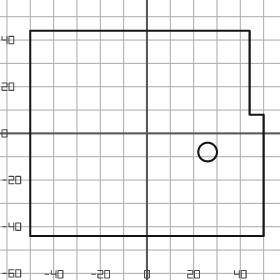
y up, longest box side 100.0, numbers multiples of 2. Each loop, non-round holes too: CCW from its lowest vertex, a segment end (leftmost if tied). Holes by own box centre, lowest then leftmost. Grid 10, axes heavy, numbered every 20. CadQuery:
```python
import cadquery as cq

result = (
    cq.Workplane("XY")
    .moveTo(-50.0, -44.0)
    .lineTo(50.0, -44.0)
    .lineTo(50.0, 8.0)
    .lineTo(44.0, 8.0)
    .lineTo(44.0, 44.0)
    .lineTo(-50.0, 44.0)
    .close()
    .moveTo(26.0, -8.0)
    .circle(4.0)
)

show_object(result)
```